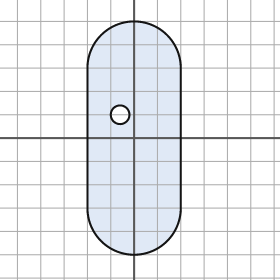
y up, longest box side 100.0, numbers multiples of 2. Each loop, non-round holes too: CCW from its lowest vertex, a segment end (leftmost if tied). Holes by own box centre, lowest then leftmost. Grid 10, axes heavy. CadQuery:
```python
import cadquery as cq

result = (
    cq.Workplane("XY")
    .moveTo(-20.0, -30.0)
    .threePointArc((0.0, -50.0), (20.0, -30.0))
    .lineTo(20.0, 30.0)
    .threePointArc((0.0, 50.0), (-20.0, 30.0))
    .close()
    .moveTo(-6.0, 10.0)
    .circle(4.0)
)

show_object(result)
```